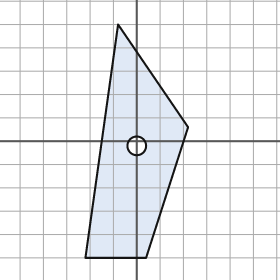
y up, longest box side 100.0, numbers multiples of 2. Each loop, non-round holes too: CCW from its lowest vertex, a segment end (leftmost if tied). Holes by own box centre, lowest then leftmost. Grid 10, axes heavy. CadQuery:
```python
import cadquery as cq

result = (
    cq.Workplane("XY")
    .moveTo(-22.0, -50.0)
    .lineTo(4.0, -50.0)
    .lineTo(22.0, 6.0)
    .lineTo(-8.0, 50.0)
    .close()
    .moveTo(0.0, -2.0)
    .circle(4.0)
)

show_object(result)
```